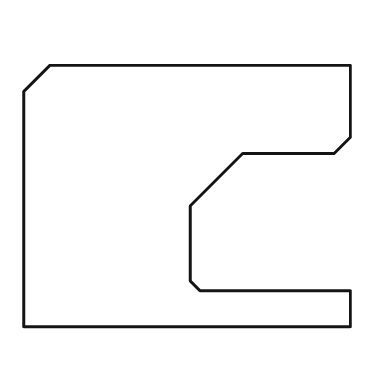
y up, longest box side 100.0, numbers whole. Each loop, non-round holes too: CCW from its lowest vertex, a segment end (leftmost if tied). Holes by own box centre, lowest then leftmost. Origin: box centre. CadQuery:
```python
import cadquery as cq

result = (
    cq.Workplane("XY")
    .moveTo(-50.0, -40.0)
    .lineTo(50.0, -40.0)
    .lineTo(50.0, -29.0)
    .lineTo(4.0, -29.0)
    .lineTo(1.0, -26.0)
    .lineTo(1.0, -3.0)
    .lineTo(17.0, 13.0)
    .lineTo(45.0, 13.0)
    .lineTo(50.0, 18.0)
    .lineTo(50.0, 40.0)
    .lineTo(-42.0, 40.0)
    .lineTo(-50.0, 32.0)
    .close()
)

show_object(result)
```